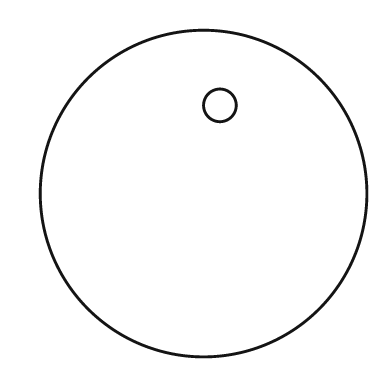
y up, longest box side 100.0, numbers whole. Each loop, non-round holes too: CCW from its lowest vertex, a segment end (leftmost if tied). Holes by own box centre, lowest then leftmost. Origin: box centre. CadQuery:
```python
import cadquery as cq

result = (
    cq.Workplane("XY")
    .moveTo(0.0, 0.0)
    .circle(50.0)
    .moveTo(5.0, 27.0)
    .circle(5.0)
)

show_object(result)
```